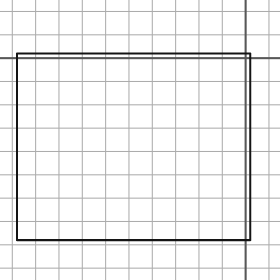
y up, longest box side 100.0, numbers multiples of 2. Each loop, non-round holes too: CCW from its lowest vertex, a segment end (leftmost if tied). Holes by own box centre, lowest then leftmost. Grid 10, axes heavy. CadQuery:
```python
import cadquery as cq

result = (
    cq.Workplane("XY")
    .moveTo(-98.0, -78.0)
    .lineTo(2.0, -78.0)
    .lineTo(2.0, 2.0)
    .lineTo(-98.0, 2.0)
    .close()
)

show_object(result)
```